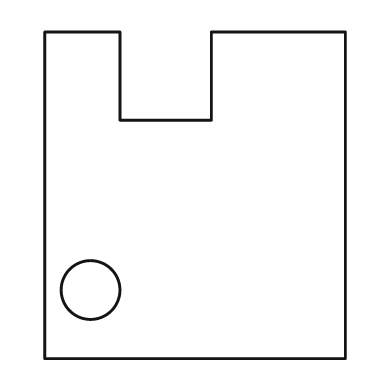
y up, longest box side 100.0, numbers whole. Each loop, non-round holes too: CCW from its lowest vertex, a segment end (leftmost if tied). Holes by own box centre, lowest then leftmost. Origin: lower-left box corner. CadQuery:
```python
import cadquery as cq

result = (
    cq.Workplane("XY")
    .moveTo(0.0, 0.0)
    .lineTo(92.0, 0.0)
    .lineTo(92.0, 100.0)
    .lineTo(51.0, 100.0)
    .lineTo(51.0, 73.0)
    .lineTo(23.0, 73.0)
    .lineTo(23.0, 100.0)
    .lineTo(0.0, 100.0)
    .close()
    .moveTo(14.0, 21.0)
    .circle(9.0)
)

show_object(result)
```